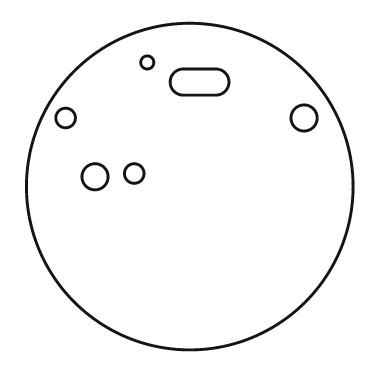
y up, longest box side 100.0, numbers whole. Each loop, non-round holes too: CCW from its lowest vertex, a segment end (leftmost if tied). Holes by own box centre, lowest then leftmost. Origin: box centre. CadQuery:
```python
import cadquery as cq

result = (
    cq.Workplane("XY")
    .moveTo(0.0, 0.0)
    .circle(50.0)
    .moveTo(-29.0, 3.0)
    .circle(4.0)
    .moveTo(-17.0, 4.0)
    .circle(3.0)
    .moveTo(-38.0, 21.0)
    .circle(3.0)
    .moveTo(35.0, 21.0)
    .circle(4.0)
    .moveTo(-2.0, 28.0)
    .lineTo(8.0, 28.0)
    .threePointArc((12.0, 32.0), (8.0, 36.0))
    .lineTo(-2.0, 36.0)
    .threePointArc((-6.0, 32.0), (-2.0, 28.0))
    .close()
    .moveTo(-13.0, 38.0)
    .circle(2.0)
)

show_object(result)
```